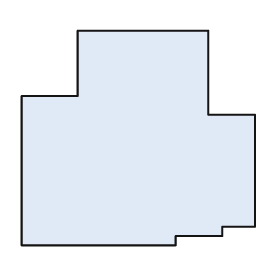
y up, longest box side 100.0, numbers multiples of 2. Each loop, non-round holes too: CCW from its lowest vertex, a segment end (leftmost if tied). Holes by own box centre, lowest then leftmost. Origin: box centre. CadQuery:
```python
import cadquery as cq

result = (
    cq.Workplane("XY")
    .moveTo(-50.0, -46.0)
    .lineTo(16.0, -46.0)
    .lineTo(16.0, -42.0)
    .lineTo(36.0, -42.0)
    .lineTo(36.0, -38.0)
    .lineTo(50.0, -38.0)
    .lineTo(50.0, 10.0)
    .lineTo(30.0, 10.0)
    .lineTo(30.0, 46.0)
    .lineTo(-26.0, 46.0)
    .lineTo(-26.0, 18.0)
    .lineTo(-50.0, 18.0)
    .close()
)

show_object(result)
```